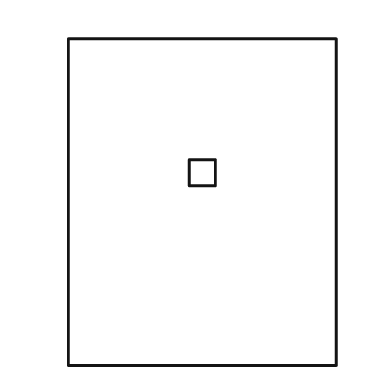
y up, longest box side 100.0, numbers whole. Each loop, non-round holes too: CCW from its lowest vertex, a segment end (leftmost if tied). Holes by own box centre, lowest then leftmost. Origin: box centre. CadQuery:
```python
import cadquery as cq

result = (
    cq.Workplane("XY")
    .moveTo(-41.0, -50.0)
    .lineTo(41.0, -50.0)
    .lineTo(41.0, 50.0)
    .lineTo(-41.0, 50.0)
    .close()
    .moveTo(-4.0, 5.0)
    .lineTo(4.0, 5.0)
    .lineTo(4.0, 13.0)
    .lineTo(-4.0, 13.0)
    .close()
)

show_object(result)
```